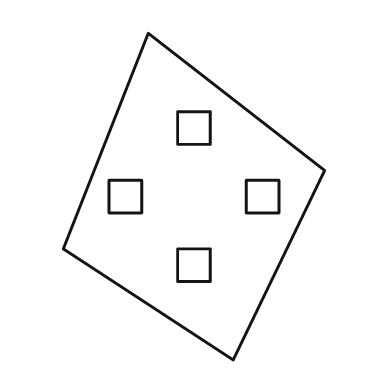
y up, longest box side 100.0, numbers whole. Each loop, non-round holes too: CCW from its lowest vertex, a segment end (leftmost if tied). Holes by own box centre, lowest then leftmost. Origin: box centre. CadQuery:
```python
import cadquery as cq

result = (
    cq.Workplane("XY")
    .moveTo(12.0, -50.0)
    .lineTo(40.0, 8.0)
    .lineTo(-14.0, 50.0)
    .lineTo(-40.0, -16.0)
    .close()
    .moveTo(-5.0, -26.0)
    .lineTo(5.0, -26.0)
    .lineTo(5.0, -16.0)
    .lineTo(-5.0, -16.0)
    .close()
    .moveTo(-26.0, -5.0)
    .lineTo(-16.0, -5.0)
    .lineTo(-16.0, 5.0)
    .lineTo(-26.0, 5.0)
    .close()
    .moveTo(16.0, -5.0)
    .lineTo(26.0, -5.0)
    .lineTo(26.0, 5.0)
    .lineTo(16.0, 5.0)
    .close()
    .moveTo(-5.0, 16.0)
    .lineTo(5.0, 16.0)
    .lineTo(5.0, 26.0)
    .lineTo(-5.0, 26.0)
    .close()
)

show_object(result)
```